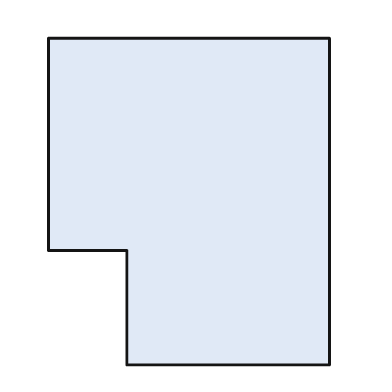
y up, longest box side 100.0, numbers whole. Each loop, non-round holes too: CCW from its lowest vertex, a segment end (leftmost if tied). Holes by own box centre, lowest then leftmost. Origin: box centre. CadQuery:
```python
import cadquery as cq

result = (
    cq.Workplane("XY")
    .moveTo(-19.0, -50.0)
    .lineTo(43.0, -50.0)
    .lineTo(43.0, 50.0)
    .lineTo(-43.0, 50.0)
    .lineTo(-43.0, -15.0)
    .lineTo(-19.0, -15.0)
    .close()
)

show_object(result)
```